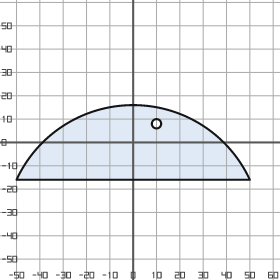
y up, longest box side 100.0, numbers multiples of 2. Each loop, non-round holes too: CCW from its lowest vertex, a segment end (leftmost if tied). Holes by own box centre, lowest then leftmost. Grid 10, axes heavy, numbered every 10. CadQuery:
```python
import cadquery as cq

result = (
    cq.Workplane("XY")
    .moveTo(-50.0, -16.0)
    .lineTo(50.0, -16.0)
    .threePointArc((0.0, 16.0), (-50.0, -16.0))
    .close()
    .moveTo(10.0, 8.0)
    .circle(2.0)
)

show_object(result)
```